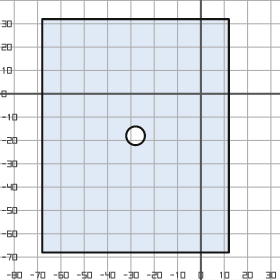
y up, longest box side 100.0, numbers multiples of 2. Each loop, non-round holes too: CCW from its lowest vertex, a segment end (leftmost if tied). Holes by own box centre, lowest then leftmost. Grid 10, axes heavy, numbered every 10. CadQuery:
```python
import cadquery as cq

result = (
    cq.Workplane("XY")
    .moveTo(-68.0, -68.0)
    .lineTo(12.0, -68.0)
    .lineTo(12.0, 32.0)
    .lineTo(-68.0, 32.0)
    .close()
    .moveTo(-28.0, -18.0)
    .circle(4.0)
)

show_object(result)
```